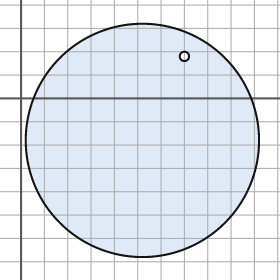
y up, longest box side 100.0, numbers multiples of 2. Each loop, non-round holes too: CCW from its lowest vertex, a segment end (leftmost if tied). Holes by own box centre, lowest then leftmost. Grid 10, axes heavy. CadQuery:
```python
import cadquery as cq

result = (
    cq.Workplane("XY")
    .moveTo(52.0, -18.0)
    .circle(50.0)
    .moveTo(70.0, 18.0)
    .circle(2.0)
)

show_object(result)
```